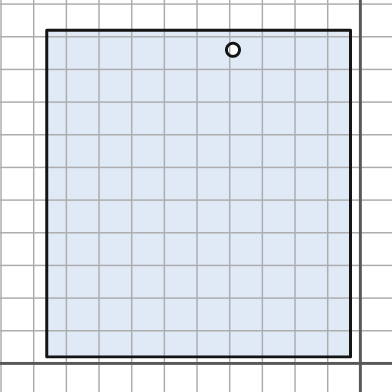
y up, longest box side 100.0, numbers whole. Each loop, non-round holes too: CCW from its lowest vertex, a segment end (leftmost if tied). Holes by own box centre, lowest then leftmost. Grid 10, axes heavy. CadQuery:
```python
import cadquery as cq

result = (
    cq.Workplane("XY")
    .moveTo(-96.0, 2.0)
    .lineTo(-3.0, 2.0)
    .lineTo(-3.0, 102.0)
    .lineTo(-96.0, 102.0)
    .close()
    .moveTo(-39.0, 96.0)
    .circle(2.0)
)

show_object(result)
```